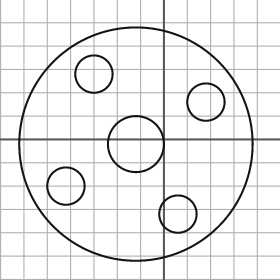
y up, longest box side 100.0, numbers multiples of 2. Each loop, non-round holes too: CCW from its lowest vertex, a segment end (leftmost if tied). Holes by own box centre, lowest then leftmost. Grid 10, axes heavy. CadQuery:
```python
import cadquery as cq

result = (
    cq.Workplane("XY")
    .moveTo(-12.0, -2.0)
    .circle(50.0)
    .moveTo(6.0, -32.0)
    .circle(8.0)
    .moveTo(-42.0, -20.0)
    .circle(8.0)
    .moveTo(-12.0, -2.0)
    .circle(12.0)
    .moveTo(18.0, 16.0)
    .circle(8.0)
    .moveTo(-30.0, 28.0)
    .circle(8.0)
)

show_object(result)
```